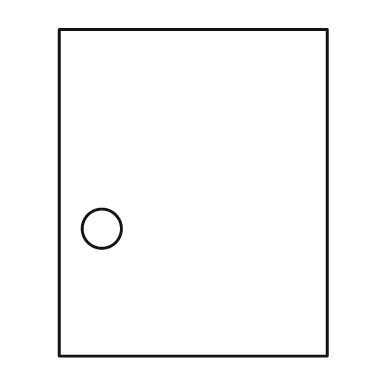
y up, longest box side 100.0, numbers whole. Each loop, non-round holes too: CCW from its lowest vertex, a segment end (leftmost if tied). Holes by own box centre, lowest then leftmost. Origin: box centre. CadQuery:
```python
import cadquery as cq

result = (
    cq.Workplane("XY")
    .moveTo(-41.0, -50.0)
    .lineTo(41.0, -50.0)
    .lineTo(41.0, 50.0)
    .lineTo(-41.0, 50.0)
    .close()
    .moveTo(-28.0, -11.0)
    .circle(6.0)
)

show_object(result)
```